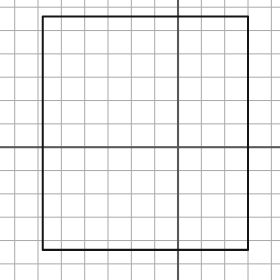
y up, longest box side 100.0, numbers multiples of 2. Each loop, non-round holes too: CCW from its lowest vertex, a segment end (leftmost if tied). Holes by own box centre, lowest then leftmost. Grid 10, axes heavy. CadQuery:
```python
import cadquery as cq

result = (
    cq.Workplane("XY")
    .moveTo(-58.0, -44.0)
    .lineTo(30.0, -44.0)
    .lineTo(30.0, 56.0)
    .lineTo(-58.0, 56.0)
    .close()
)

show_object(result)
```